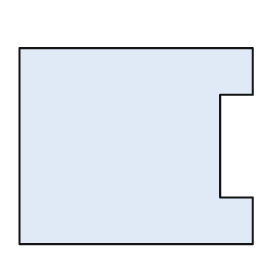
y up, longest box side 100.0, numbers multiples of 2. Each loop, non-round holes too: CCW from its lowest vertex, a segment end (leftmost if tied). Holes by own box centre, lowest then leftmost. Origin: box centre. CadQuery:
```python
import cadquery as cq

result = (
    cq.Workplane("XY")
    .moveTo(-50.0, -42.0)
    .lineTo(50.0, -42.0)
    .lineTo(50.0, -22.0)
    .lineTo(36.0, -22.0)
    .lineTo(36.0, 22.0)
    .lineTo(50.0, 22.0)
    .lineTo(50.0, 42.0)
    .lineTo(-50.0, 42.0)
    .close()
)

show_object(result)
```